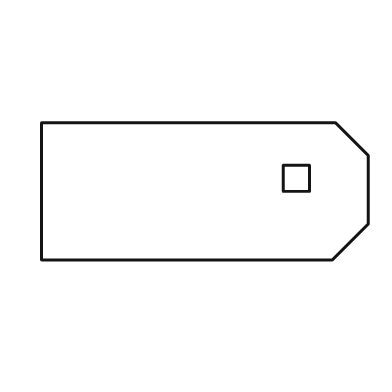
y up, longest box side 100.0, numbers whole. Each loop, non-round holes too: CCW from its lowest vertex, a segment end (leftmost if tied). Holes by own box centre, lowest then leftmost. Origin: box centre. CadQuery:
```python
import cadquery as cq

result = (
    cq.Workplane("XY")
    .moveTo(-50.0, -21.0)
    .lineTo(39.0, -21.0)
    .lineTo(50.0, -10.0)
    .lineTo(50.0, 11.0)
    .lineTo(40.0, 21.0)
    .lineTo(-50.0, 21.0)
    .close()
    .moveTo(24.0, 0.0)
    .lineTo(32.0, 0.0)
    .lineTo(32.0, 8.0)
    .lineTo(24.0, 8.0)
    .close()
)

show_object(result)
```